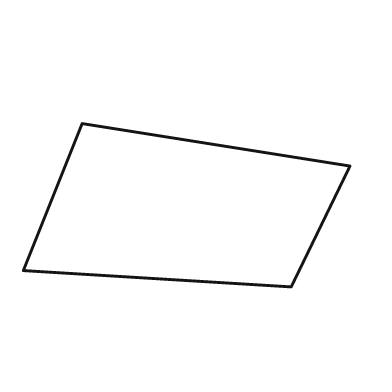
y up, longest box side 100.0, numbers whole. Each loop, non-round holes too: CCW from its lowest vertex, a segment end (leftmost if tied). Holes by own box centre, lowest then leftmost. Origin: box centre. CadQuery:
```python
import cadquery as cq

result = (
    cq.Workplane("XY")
    .moveTo(32.0, -25.0)
    .lineTo(50.0, 12.0)
    .lineTo(-32.0, 25.0)
    .lineTo(-50.0, -20.0)
    .close()
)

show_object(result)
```